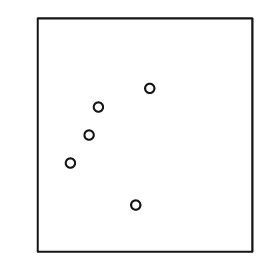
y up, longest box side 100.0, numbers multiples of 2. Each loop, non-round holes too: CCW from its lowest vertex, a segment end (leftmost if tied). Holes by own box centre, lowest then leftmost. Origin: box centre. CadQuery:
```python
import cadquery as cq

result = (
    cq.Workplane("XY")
    .moveTo(-46.0, -50.0)
    .lineTo(46.0, -50.0)
    .lineTo(46.0, 50.0)
    .lineTo(-46.0, 50.0)
    .close()
    .moveTo(-4.0, -30.0)
    .circle(2.0)
    .moveTo(-32.0, -12.0)
    .circle(2.0)
    .moveTo(-24.0, 0.0)
    .circle(2.0)
    .moveTo(-20.0, 12.0)
    .circle(2.0)
    .moveTo(2.0, 20.0)
    .circle(2.0)
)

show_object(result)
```